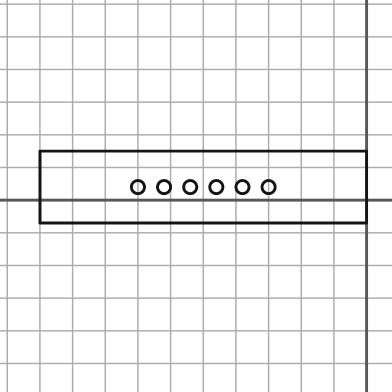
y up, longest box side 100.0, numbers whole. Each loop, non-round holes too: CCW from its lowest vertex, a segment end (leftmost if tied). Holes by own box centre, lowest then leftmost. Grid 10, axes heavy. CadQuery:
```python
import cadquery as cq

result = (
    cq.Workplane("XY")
    .moveTo(-100.0, -7.0)
    .lineTo(0.0, -7.0)
    .lineTo(0.0, 15.0)
    .lineTo(-100.0, 15.0)
    .close()
    .moveTo(-70.0, 4.0)
    .circle(2.0)
    .moveTo(-62.0, 4.0)
    .circle(2.0)
    .moveTo(-54.0, 4.0)
    .circle(2.0)
    .moveTo(-46.0, 4.0)
    .circle(2.0)
    .moveTo(-38.0, 4.0)
    .circle(2.0)
    .moveTo(-30.0, 4.0)
    .circle(2.0)
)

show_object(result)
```